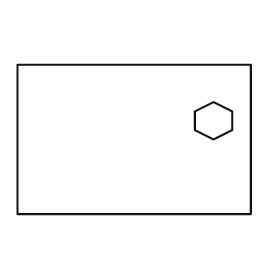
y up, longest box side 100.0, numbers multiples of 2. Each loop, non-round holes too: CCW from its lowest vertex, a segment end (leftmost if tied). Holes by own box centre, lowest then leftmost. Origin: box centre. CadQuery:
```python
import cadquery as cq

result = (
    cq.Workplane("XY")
    .moveTo(-50.0, -32.0)
    .lineTo(50.0, -32.0)
    .lineTo(50.0, 32.0)
    .lineTo(-50.0, 32.0)
    .close()
    .moveTo(34.0, 0.0)
    .lineTo(42.0, 4.0)
    .lineTo(42.0, 12.0)
    .lineTo(34.0, 16.0)
    .lineTo(26.0, 12.0)
    .lineTo(26.0, 4.0)
    .close()
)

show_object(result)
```